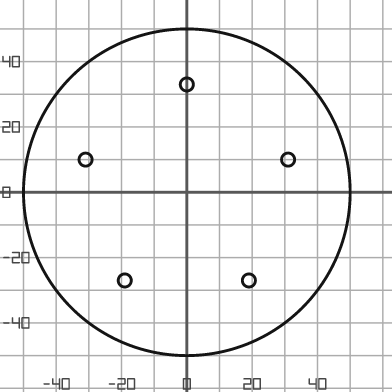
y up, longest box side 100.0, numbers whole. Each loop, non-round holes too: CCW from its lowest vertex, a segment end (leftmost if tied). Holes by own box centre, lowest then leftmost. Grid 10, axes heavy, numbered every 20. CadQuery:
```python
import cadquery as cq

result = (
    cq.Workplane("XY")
    .moveTo(0.0, 0.0)
    .circle(50.0)
    .moveTo(-19.0, -27.0)
    .circle(2.0)
    .moveTo(19.0, -27.0)
    .circle(2.0)
    .moveTo(-31.0, 10.0)
    .circle(2.0)
    .moveTo(31.0, 10.0)
    .circle(2.0)
    .moveTo(0.0, 33.0)
    .circle(2.0)
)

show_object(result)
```